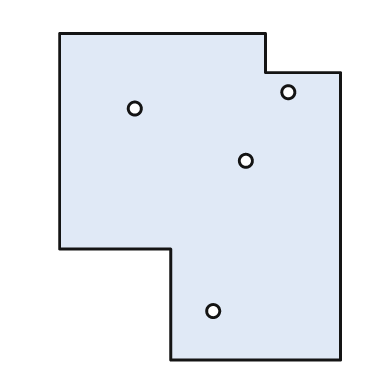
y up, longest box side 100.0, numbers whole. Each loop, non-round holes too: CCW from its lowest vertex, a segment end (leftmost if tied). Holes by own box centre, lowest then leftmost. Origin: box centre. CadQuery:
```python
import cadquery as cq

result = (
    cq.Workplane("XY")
    .moveTo(-9.0, -50.0)
    .lineTo(43.0, -50.0)
    .lineTo(43.0, 38.0)
    .lineTo(20.0, 38.0)
    .lineTo(20.0, 50.0)
    .lineTo(-43.0, 50.0)
    .lineTo(-43.0, -16.0)
    .lineTo(-9.0, -16.0)
    .close()
    .moveTo(4.0, -35.0)
    .circle(2.0)
    .moveTo(14.0, 11.0)
    .circle(2.0)
    .moveTo(-20.0, 27.0)
    .circle(2.0)
    .moveTo(27.0, 32.0)
    .circle(2.0)
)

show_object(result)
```